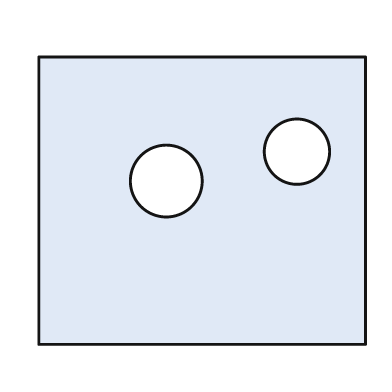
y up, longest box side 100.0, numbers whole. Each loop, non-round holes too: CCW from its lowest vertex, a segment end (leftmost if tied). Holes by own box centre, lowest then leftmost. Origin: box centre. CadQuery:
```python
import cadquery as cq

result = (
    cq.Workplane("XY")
    .moveTo(-50.0, -44.0)
    .lineTo(50.0, -44.0)
    .lineTo(50.0, 44.0)
    .lineTo(-50.0, 44.0)
    .close()
    .moveTo(-11.0, 6.0)
    .circle(11.0)
    .moveTo(29.0, 15.0)
    .circle(10.0)
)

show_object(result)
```